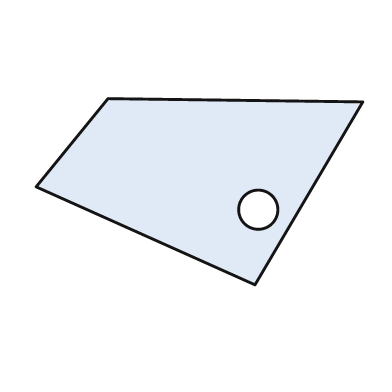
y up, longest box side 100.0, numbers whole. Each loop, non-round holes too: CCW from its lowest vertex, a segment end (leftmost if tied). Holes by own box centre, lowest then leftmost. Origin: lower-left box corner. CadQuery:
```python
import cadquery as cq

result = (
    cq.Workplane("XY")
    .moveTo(67.0, 0.0)
    .lineTo(100.0, 56.0)
    .lineTo(22.0, 57.0)
    .lineTo(0.0, 30.0)
    .close()
    .moveTo(68.0, 23.0)
    .circle(6.0)
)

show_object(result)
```